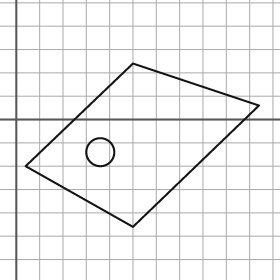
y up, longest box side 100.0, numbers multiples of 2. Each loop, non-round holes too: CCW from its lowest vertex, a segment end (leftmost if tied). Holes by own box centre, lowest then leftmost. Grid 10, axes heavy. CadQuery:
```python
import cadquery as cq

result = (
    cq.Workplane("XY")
    .moveTo(50.0, -46.0)
    .lineTo(104.0, 6.0)
    .lineTo(50.0, 24.0)
    .lineTo(4.0, -20.0)
    .close()
    .moveTo(36.0, -14.0)
    .circle(6.0)
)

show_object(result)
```